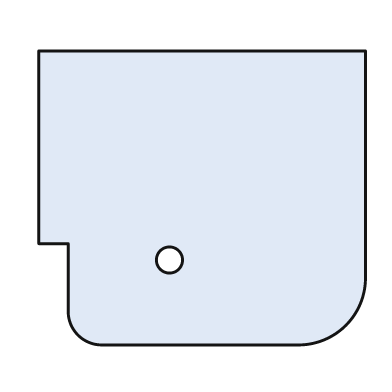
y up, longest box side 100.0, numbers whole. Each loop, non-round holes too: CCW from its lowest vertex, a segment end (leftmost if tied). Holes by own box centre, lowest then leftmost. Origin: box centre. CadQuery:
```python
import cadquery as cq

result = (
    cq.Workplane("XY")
    .moveTo(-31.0, -45.0)
    .lineTo(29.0, -45.0)
    .threePointArc((44.0, -39.0), (50.0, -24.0))
    .lineTo(50.0, 45.0)
    .lineTo(-50.0, 45.0)
    .lineTo(-50.0, -14.0)
    .lineTo(-41.0, -14.0)
    .lineTo(-41.0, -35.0)
    .threePointArc((-38.0, -42.0), (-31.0, -45.0))
    .close()
    .moveTo(-10.0, -19.0)
    .circle(4.0)
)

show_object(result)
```